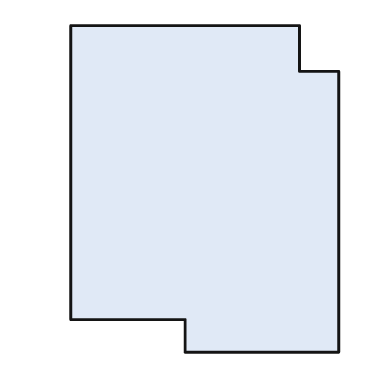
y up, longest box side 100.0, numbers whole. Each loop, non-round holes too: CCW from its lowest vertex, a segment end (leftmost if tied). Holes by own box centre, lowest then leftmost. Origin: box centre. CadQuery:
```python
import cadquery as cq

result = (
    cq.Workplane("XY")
    .moveTo(-6.0, -50.0)
    .lineTo(41.0, -50.0)
    .lineTo(41.0, 36.0)
    .lineTo(29.0, 36.0)
    .lineTo(29.0, 50.0)
    .lineTo(-41.0, 50.0)
    .lineTo(-41.0, -40.0)
    .lineTo(-6.0, -40.0)
    .close()
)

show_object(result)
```